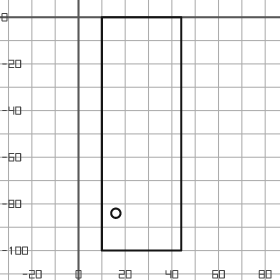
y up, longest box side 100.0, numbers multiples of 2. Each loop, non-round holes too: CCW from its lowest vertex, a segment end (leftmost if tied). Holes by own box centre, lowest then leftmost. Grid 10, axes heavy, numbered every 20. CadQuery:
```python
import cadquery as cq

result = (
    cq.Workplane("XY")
    .moveTo(10.0, -100.0)
    .lineTo(44.0, -100.0)
    .lineTo(44.0, 0.0)
    .lineTo(10.0, 0.0)
    .close()
    .moveTo(16.0, -84.0)
    .circle(2.0)
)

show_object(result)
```